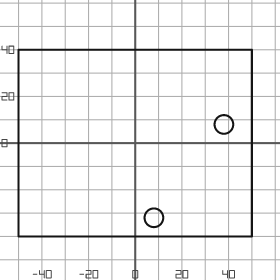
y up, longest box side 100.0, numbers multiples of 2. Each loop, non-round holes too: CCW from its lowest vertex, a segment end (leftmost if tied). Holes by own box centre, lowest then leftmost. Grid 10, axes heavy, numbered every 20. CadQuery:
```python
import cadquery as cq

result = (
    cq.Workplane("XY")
    .moveTo(-50.0, -40.0)
    .lineTo(50.0, -40.0)
    .lineTo(50.0, 40.0)
    .lineTo(-50.0, 40.0)
    .close()
    .moveTo(8.0, -32.0)
    .circle(4.0)
    .moveTo(38.0, 8.0)
    .circle(4.0)
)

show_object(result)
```